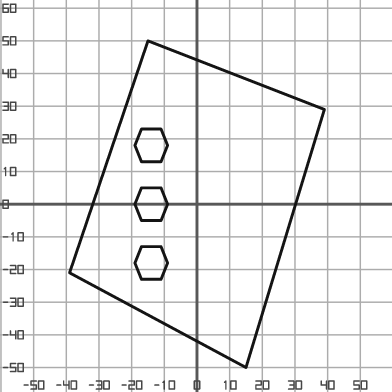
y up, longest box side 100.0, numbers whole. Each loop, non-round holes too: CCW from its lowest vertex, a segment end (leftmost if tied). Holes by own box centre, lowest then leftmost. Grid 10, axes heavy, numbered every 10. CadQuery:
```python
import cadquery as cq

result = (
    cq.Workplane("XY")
    .moveTo(15.0, -50.0)
    .lineTo(39.0, 29.0)
    .lineTo(-15.0, 50.0)
    .lineTo(-39.0, -21.0)
    .close()
    .moveTo(-17.0, -23.0)
    .lineTo(-11.0, -23.0)
    .lineTo(-9.0, -18.0)
    .lineTo(-11.0, -13.0)
    .lineTo(-17.0, -13.0)
    .lineTo(-19.0, -18.0)
    .close()
    .moveTo(-17.0, -5.0)
    .lineTo(-11.0, -5.0)
    .lineTo(-9.0, 0.0)
    .lineTo(-11.0, 5.0)
    .lineTo(-17.0, 5.0)
    .lineTo(-19.0, 0.0)
    .close()
    .moveTo(-17.0, 13.0)
    .lineTo(-11.0, 13.0)
    .lineTo(-9.0, 18.0)
    .lineTo(-11.0, 23.0)
    .lineTo(-17.0, 23.0)
    .lineTo(-19.0, 18.0)
    .close()
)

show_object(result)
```